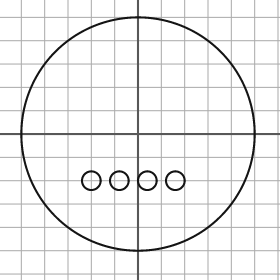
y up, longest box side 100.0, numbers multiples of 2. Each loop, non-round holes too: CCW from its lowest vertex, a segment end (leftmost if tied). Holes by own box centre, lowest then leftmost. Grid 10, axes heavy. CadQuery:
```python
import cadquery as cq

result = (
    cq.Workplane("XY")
    .moveTo(0.0, 0.0)
    .circle(50.0)
    .moveTo(-20.0, -20.0)
    .circle(4.0)
    .moveTo(-8.0, -20.0)
    .circle(4.0)
    .moveTo(4.0, -20.0)
    .circle(4.0)
    .moveTo(16.0, -20.0)
    .circle(4.0)
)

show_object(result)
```